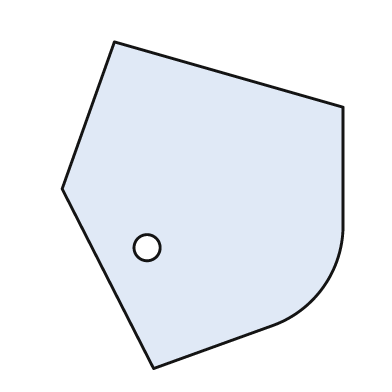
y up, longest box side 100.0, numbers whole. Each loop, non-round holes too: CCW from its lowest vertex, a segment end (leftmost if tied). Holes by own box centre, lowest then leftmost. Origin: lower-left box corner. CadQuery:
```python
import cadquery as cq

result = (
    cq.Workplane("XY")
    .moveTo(28.0, 0.0)
    .lineTo(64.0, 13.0)
    .threePointArc((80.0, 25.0), (86.0, 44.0))
    .lineTo(86.0, 80.0)
    .lineTo(16.0, 100.0)
    .lineTo(0.0, 55.0)
    .close()
    .moveTo(26.0, 37.0)
    .circle(4.0)
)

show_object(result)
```